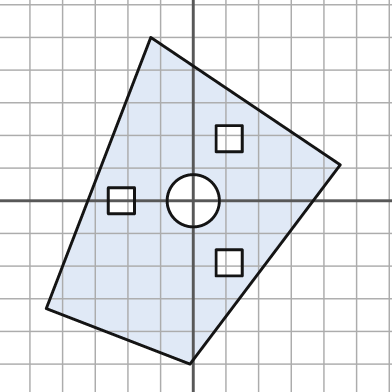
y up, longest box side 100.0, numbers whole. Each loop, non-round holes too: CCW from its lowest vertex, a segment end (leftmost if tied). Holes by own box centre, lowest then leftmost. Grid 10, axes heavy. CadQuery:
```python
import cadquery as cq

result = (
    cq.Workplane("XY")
    .moveTo(-1.0, -50.0)
    .lineTo(45.0, 11.0)
    .lineTo(-13.0, 50.0)
    .lineTo(-45.0, -33.0)
    .close()
    .moveTo(7.0, -23.0)
    .lineTo(15.0, -23.0)
    .lineTo(15.0, -15.0)
    .lineTo(7.0, -15.0)
    .close()
    .moveTo(-26.0, -4.0)
    .lineTo(-18.0, -4.0)
    .lineTo(-18.0, 4.0)
    .lineTo(-26.0, 4.0)
    .close()
    .moveTo(0.0, 0.0)
    .circle(8.0)
    .moveTo(7.0, 15.0)
    .lineTo(15.0, 15.0)
    .lineTo(15.0, 23.0)
    .lineTo(7.0, 23.0)
    .close()
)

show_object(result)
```